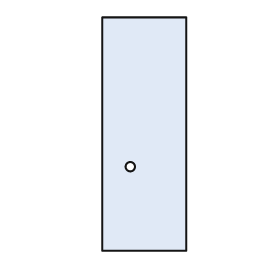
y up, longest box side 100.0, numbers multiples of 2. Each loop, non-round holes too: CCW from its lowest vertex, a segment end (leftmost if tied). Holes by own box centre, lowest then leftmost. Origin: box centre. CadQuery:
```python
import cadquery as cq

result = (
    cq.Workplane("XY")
    .moveTo(-18.0, -50.0)
    .lineTo(18.0, -50.0)
    .lineTo(18.0, 50.0)
    .lineTo(-18.0, 50.0)
    .close()
    .moveTo(-6.0, -14.0)
    .circle(2.0)
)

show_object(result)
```